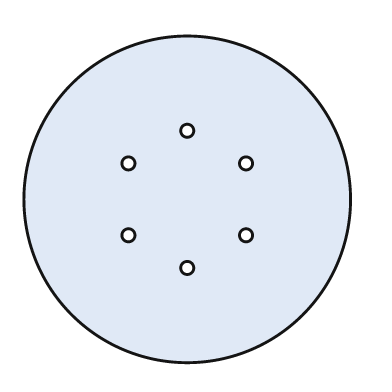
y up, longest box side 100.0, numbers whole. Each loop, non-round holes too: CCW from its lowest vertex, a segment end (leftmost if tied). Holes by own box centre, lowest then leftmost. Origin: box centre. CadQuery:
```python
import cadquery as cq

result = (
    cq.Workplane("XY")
    .moveTo(0.0, 0.0)
    .circle(50.0)
    .moveTo(0.0, -21.0)
    .circle(2.0)
    .moveTo(-18.0, -11.0)
    .circle(2.0)
    .moveTo(18.0, -11.0)
    .circle(2.0)
    .moveTo(-18.0, 11.0)
    .circle(2.0)
    .moveTo(18.0, 11.0)
    .circle(2.0)
    .moveTo(0.0, 21.0)
    .circle(2.0)
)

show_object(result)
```